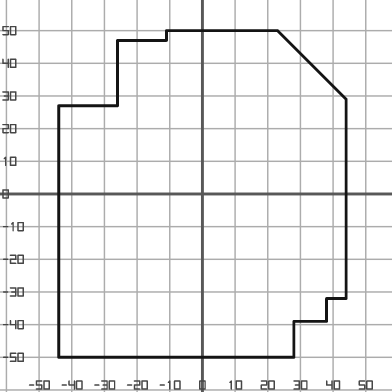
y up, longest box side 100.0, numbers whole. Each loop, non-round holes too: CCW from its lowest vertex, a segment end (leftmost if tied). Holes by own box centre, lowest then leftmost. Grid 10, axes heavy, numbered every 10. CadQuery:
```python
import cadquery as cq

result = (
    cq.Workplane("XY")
    .moveTo(-44.0, -50.0)
    .lineTo(28.0, -50.0)
    .lineTo(28.0, -39.0)
    .lineTo(38.0, -39.0)
    .lineTo(38.0, -32.0)
    .lineTo(44.0, -32.0)
    .lineTo(44.0, 29.0)
    .lineTo(23.0, 50.0)
    .lineTo(-11.0, 50.0)
    .lineTo(-11.0, 47.0)
    .lineTo(-26.0, 47.0)
    .lineTo(-26.0, 27.0)
    .lineTo(-44.0, 27.0)
    .close()
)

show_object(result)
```